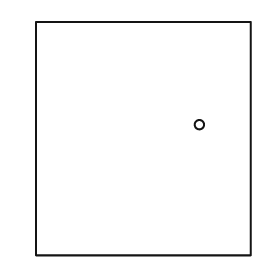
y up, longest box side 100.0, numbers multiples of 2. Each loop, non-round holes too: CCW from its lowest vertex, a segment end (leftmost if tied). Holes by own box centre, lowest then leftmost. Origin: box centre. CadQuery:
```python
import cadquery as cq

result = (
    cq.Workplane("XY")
    .moveTo(-46.0, -50.0)
    .lineTo(46.0, -50.0)
    .lineTo(46.0, 50.0)
    .lineTo(-46.0, 50.0)
    .close()
    .moveTo(24.0, 6.0)
    .circle(2.0)
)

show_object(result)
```